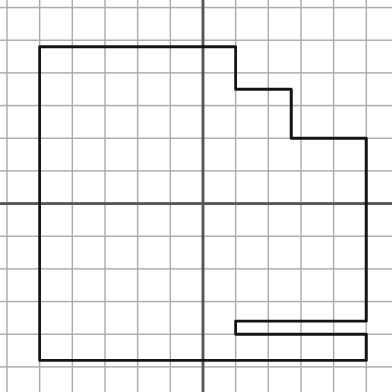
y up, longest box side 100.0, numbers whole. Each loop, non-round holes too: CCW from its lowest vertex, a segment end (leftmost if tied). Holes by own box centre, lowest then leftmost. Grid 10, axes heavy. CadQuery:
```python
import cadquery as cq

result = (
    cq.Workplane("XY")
    .moveTo(-50.0, -48.0)
    .lineTo(50.0, -48.0)
    .lineTo(50.0, -40.0)
    .lineTo(10.0, -40.0)
    .lineTo(10.0, -36.0)
    .lineTo(50.0, -36.0)
    .lineTo(50.0, 20.0)
    .lineTo(27.0, 20.0)
    .lineTo(27.0, 35.0)
    .lineTo(10.0, 35.0)
    .lineTo(10.0, 48.0)
    .lineTo(-50.0, 48.0)
    .close()
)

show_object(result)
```